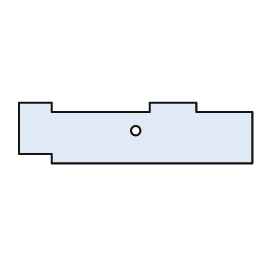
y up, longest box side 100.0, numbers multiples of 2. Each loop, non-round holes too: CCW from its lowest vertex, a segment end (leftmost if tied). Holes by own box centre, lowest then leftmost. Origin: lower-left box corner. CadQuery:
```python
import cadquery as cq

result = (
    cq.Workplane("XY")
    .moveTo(14.0, 0.0)
    .lineTo(100.0, 0.0)
    .lineTo(100.0, 22.0)
    .lineTo(76.0, 22.0)
    .lineTo(76.0, 26.0)
    .lineTo(56.0, 26.0)
    .lineTo(56.0, 22.0)
    .lineTo(14.0, 22.0)
    .lineTo(14.0, 26.0)
    .lineTo(0.0, 26.0)
    .lineTo(0.0, 4.0)
    .lineTo(14.0, 4.0)
    .close()
    .moveTo(50.0, 14.0)
    .circle(2.0)
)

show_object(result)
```